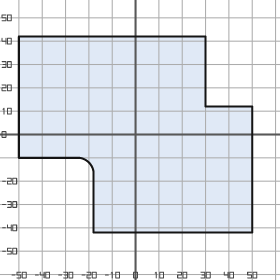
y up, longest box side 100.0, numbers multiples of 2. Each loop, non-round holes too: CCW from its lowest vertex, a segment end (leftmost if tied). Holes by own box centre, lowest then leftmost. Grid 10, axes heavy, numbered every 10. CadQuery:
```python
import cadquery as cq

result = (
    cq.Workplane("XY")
    .moveTo(-18.0, -42.0)
    .lineTo(50.0, -42.0)
    .lineTo(50.0, 12.0)
    .lineTo(30.0, 12.0)
    .lineTo(30.0, 42.0)
    .lineTo(-50.0, 42.0)
    .lineTo(-50.0, -10.0)
    .lineTo(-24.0, -10.0)
    .threePointArc((-20.0, -12.0), (-18.0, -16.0))
    .close()
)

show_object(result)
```